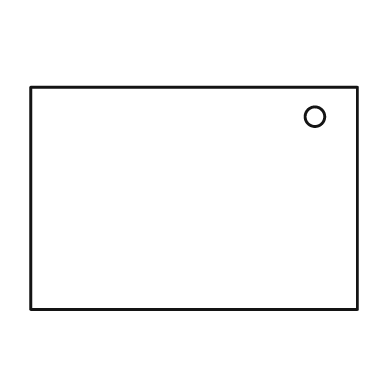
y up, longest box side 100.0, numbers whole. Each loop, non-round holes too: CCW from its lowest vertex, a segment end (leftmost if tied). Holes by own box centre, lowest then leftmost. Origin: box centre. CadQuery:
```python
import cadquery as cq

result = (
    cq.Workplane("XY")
    .moveTo(-50.0, -34.0)
    .lineTo(50.0, -34.0)
    .lineTo(50.0, 34.0)
    .lineTo(-50.0, 34.0)
    .close()
    .moveTo(37.0, 25.0)
    .circle(3.0)
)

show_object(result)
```